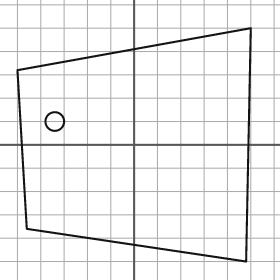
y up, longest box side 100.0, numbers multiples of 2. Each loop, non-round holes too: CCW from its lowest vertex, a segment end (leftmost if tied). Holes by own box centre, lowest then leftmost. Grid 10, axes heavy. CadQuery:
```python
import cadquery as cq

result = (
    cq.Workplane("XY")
    .moveTo(48.0, -50.0)
    .lineTo(50.0, 50.0)
    .lineTo(-50.0, 32.0)
    .lineTo(-46.0, -36.0)
    .close()
    .moveTo(-34.0, 10.0)
    .circle(4.0)
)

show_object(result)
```